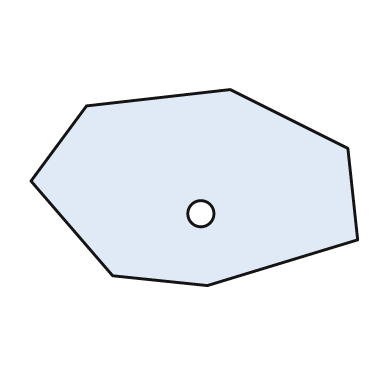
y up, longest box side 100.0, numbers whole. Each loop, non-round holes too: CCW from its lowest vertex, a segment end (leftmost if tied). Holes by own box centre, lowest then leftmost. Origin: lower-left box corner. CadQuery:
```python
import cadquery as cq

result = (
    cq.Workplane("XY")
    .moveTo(54.0, 0.0)
    .lineTo(100.0, 14.0)
    .lineTo(97.0, 42.0)
    .lineTo(61.0, 60.0)
    .lineTo(17.0, 55.0)
    .lineTo(0.0, 32.0)
    .lineTo(25.0, 3.0)
    .close()
    .moveTo(52.0, 22.0)
    .circle(4.0)
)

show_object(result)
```